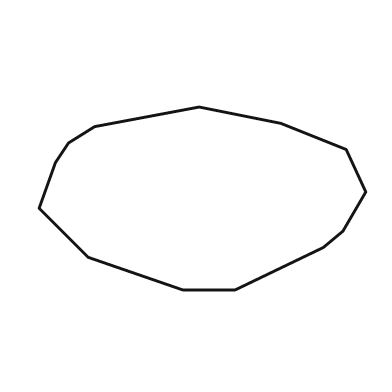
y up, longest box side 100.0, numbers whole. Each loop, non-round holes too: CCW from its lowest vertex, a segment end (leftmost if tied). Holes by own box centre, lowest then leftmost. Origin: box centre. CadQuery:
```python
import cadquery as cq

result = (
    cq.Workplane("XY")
    .moveTo(-6.0, -28.0)
    .lineTo(10.0, -28.0)
    .lineTo(37.0, -15.0)
    .lineTo(43.0, -10.0)
    .lineTo(50.0, 2.0)
    .lineTo(44.0, 15.0)
    .lineTo(24.0, 23.0)
    .lineTo(-1.0, 28.0)
    .lineTo(-33.0, 22.0)
    .lineTo(-41.0, 17.0)
    .lineTo(-45.0, 11.0)
    .lineTo(-50.0, -3.0)
    .lineTo(-35.0, -18.0)
    .close()
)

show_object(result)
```